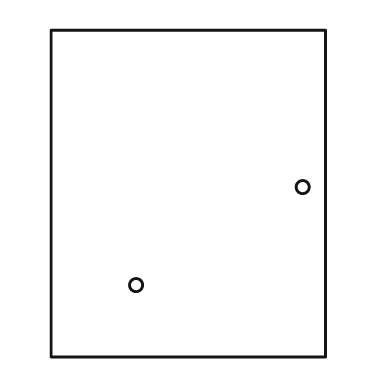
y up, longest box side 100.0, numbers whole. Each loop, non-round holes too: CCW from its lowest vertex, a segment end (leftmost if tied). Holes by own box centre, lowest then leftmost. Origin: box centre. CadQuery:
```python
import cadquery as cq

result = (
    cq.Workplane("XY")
    .moveTo(-42.0, -50.0)
    .lineTo(42.0, -50.0)
    .lineTo(42.0, 50.0)
    .lineTo(-42.0, 50.0)
    .close()
    .moveTo(-16.0, -28.0)
    .circle(2.0)
    .moveTo(35.0, 2.0)
    .circle(2.0)
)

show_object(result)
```